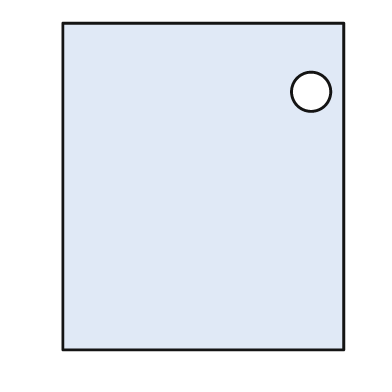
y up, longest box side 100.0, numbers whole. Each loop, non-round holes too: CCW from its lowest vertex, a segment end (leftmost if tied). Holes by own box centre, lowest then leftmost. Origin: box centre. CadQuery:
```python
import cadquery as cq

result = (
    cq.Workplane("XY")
    .moveTo(-43.0, -50.0)
    .lineTo(43.0, -50.0)
    .lineTo(43.0, 50.0)
    .lineTo(-43.0, 50.0)
    .close()
    .moveTo(33.0, 29.0)
    .circle(6.0)
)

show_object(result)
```